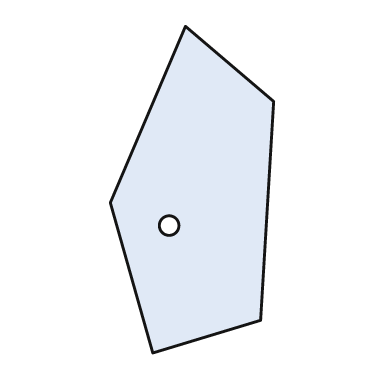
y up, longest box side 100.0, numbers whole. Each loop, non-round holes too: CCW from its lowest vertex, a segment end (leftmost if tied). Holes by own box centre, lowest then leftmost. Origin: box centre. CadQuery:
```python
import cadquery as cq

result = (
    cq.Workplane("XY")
    .moveTo(-12.0, -50.0)
    .lineTo(21.0, -40.0)
    .lineTo(25.0, 27.0)
    .lineTo(-2.0, 50.0)
    .lineTo(-25.0, -4.0)
    .close()
    .moveTo(-7.0, -11.0)
    .circle(3.0)
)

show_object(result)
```